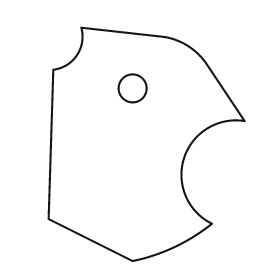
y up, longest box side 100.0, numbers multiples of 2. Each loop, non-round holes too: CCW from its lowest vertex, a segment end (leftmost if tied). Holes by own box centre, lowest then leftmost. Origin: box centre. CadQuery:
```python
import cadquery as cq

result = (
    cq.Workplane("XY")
    .moveTo(-6.0, -50.0)
    .threePointArc((12.0, -44.0), (28.0, -34.0))
    .threePointArc((16.0, -6.0), (42.0, 10.0))
    .lineTo(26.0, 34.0)
    .threePointArc((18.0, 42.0), (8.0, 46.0))
    .lineTo(-28.0, 50.0)
    .threePointArc((-30.0, 38.0), (-40.0, 32.0))
    .lineTo(-42.0, -32.0)
    .close()
    .moveTo(-6.0, 24.0)
    .circle(6.0)
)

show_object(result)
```